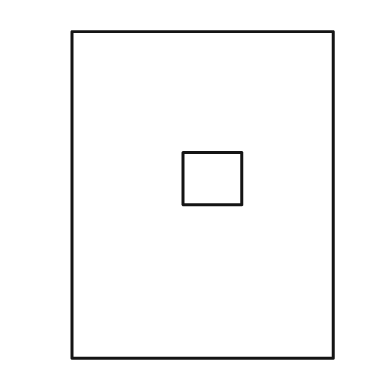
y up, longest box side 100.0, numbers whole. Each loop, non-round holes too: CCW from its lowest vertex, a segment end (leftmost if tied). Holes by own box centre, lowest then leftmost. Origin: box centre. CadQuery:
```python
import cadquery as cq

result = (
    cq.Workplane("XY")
    .moveTo(-40.0, -50.0)
    .lineTo(40.0, -50.0)
    .lineTo(40.0, 50.0)
    .lineTo(-40.0, 50.0)
    .close()
    .moveTo(-6.0, -3.0)
    .lineTo(12.0, -3.0)
    .lineTo(12.0, 13.0)
    .lineTo(-6.0, 13.0)
    .close()
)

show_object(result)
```